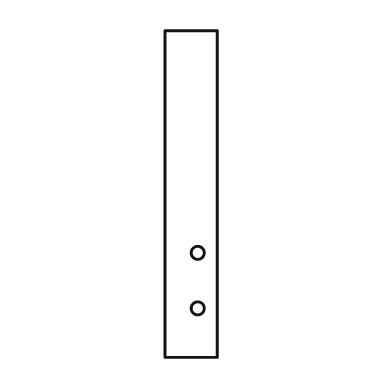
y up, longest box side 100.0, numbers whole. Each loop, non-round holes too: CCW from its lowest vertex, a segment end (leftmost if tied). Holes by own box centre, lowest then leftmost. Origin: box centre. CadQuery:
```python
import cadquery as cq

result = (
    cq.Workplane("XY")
    .moveTo(-8.0, -50.0)
    .lineTo(8.0, -50.0)
    .lineTo(8.0, 50.0)
    .lineTo(-8.0, 50.0)
    .close()
    .moveTo(2.0, -35.0)
    .circle(2.0)
    .moveTo(2.0, -18.0)
    .circle(2.0)
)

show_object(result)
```